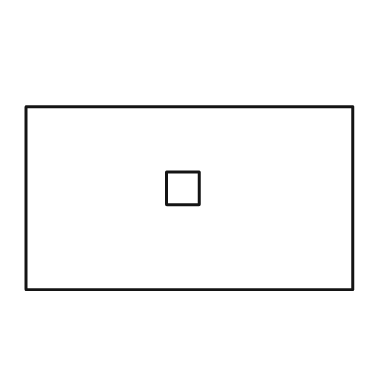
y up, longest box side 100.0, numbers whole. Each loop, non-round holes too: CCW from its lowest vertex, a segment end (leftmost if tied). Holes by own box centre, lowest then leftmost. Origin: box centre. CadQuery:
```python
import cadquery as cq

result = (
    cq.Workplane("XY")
    .moveTo(-50.0, -28.0)
    .lineTo(50.0, -28.0)
    .lineTo(50.0, 28.0)
    .lineTo(-50.0, 28.0)
    .close()
    .moveTo(-7.0, -2.0)
    .lineTo(3.0, -2.0)
    .lineTo(3.0, 8.0)
    .lineTo(-7.0, 8.0)
    .close()
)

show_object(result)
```